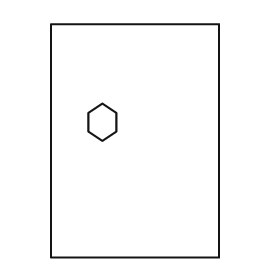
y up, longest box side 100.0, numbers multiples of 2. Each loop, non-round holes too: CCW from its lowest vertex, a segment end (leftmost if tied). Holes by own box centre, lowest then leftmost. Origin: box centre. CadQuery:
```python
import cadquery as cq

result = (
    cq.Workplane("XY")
    .moveTo(-36.0, -50.0)
    .lineTo(36.0, -50.0)
    .lineTo(36.0, 50.0)
    .lineTo(-36.0, 50.0)
    .close()
    .moveTo(-14.0, 0.0)
    .lineTo(-8.0, 4.0)
    .lineTo(-8.0, 12.0)
    .lineTo(-14.0, 16.0)
    .lineTo(-20.0, 12.0)
    .lineTo(-20.0, 4.0)
    .close()
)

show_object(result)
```